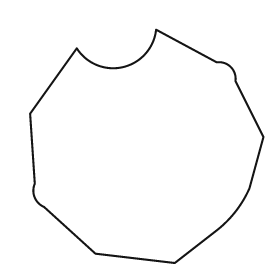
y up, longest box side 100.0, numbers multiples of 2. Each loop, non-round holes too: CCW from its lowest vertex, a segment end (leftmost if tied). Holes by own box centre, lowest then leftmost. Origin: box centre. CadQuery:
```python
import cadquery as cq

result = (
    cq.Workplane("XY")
    .moveTo(12.0, -50.0)
    .lineTo(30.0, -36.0)
    .threePointArc((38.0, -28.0), (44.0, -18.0))
    .lineTo(50.0, 4.0)
    .lineTo(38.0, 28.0)
    .threePointArc((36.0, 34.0), (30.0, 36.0))
    .lineTo(4.0, 50.0)
    .threePointArc((-10.0, 34.0), (-30.0, 42.0))
    .lineTo(-50.0, 14.0)
    .lineTo(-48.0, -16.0)
    .threePointArc((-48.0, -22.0), (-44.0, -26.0))
    .lineTo(-22.0, -46.0)
    .close()
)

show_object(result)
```